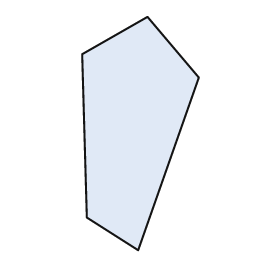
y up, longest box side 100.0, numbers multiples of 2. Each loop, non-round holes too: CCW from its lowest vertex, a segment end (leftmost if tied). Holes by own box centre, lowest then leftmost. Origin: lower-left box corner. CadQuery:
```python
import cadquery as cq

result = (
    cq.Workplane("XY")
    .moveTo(24.0, 0.0)
    .lineTo(50.0, 74.0)
    .lineTo(28.0, 100.0)
    .lineTo(0.0, 84.0)
    .lineTo(2.0, 14.0)
    .close()
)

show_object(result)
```